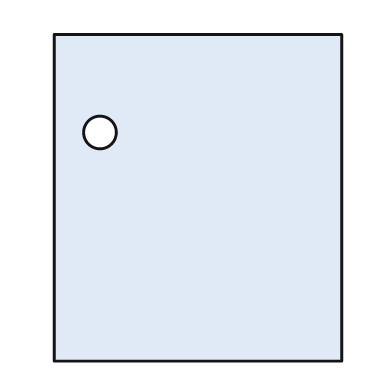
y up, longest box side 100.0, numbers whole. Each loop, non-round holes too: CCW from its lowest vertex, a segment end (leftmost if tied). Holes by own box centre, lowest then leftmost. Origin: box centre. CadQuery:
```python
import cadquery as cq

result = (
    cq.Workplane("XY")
    .moveTo(-44.0, -50.0)
    .lineTo(44.0, -50.0)
    .lineTo(44.0, 50.0)
    .lineTo(-44.0, 50.0)
    .close()
    .moveTo(-30.0, 20.0)
    .circle(5.0)
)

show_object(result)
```